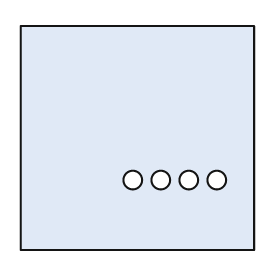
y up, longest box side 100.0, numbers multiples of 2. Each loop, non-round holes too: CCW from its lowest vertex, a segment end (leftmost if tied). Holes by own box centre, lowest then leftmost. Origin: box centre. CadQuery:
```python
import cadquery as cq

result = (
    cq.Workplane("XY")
    .moveTo(-50.0, -48.0)
    .lineTo(50.0, -48.0)
    .lineTo(50.0, 48.0)
    .lineTo(-50.0, 48.0)
    .close()
    .moveTo(-2.0, -18.0)
    .circle(4.0)
    .moveTo(10.0, -18.0)
    .circle(4.0)
    .moveTo(22.0, -18.0)
    .circle(4.0)
    .moveTo(34.0, -18.0)
    .circle(4.0)
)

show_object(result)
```